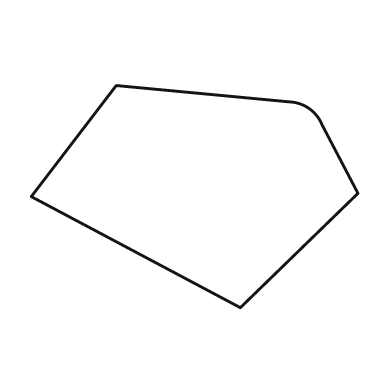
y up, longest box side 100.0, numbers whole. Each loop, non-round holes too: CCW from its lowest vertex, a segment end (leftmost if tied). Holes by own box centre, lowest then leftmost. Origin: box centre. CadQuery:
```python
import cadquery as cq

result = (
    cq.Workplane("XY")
    .moveTo(14.0, -34.0)
    .lineTo(50.0, 1.0)
    .lineTo(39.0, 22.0)
    .threePointArc((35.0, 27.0), (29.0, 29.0))
    .lineTo(-24.0, 34.0)
    .lineTo(-50.0, 0.0)
    .close()
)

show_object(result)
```